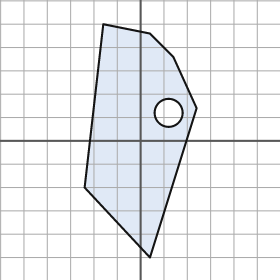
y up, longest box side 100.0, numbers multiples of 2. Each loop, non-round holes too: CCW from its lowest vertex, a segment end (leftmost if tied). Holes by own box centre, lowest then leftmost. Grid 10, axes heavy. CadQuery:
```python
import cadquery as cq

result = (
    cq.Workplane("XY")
    .moveTo(4.0, -50.0)
    .lineTo(24.0, 14.0)
    .lineTo(14.0, 36.0)
    .lineTo(4.0, 46.0)
    .lineTo(-16.0, 50.0)
    .lineTo(-24.0, -20.0)
    .close()
    .moveTo(12.0, 12.0)
    .circle(6.0)
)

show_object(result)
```